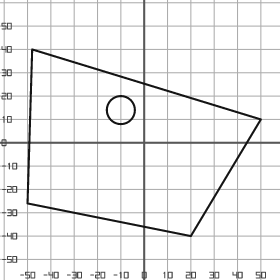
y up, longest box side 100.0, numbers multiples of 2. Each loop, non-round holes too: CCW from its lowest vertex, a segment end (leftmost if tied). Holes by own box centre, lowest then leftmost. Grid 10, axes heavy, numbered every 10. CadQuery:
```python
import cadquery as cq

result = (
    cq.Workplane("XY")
    .moveTo(20.0, -40.0)
    .lineTo(50.0, 10.0)
    .lineTo(-48.0, 40.0)
    .lineTo(-50.0, -26.0)
    .close()
    .moveTo(-10.0, 14.0)
    .circle(6.0)
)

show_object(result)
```